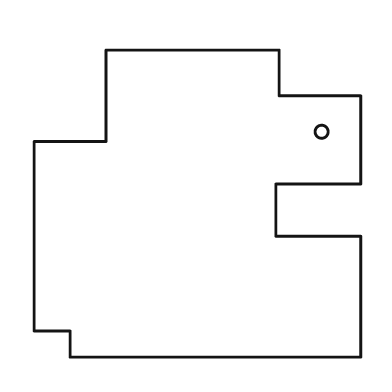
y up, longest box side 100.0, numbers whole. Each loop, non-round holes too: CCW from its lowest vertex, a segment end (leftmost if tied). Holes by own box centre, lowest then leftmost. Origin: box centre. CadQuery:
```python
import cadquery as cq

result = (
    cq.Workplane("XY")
    .moveTo(-39.0, -47.0)
    .lineTo(50.0, -47.0)
    .lineTo(50.0, -10.0)
    .lineTo(24.0, -10.0)
    .lineTo(24.0, 6.0)
    .lineTo(50.0, 6.0)
    .lineTo(50.0, 33.0)
    .lineTo(25.0, 33.0)
    .lineTo(25.0, 47.0)
    .lineTo(-28.0, 47.0)
    .lineTo(-28.0, 19.0)
    .lineTo(-50.0, 19.0)
    .lineTo(-50.0, -39.0)
    .lineTo(-39.0, -39.0)
    .close()
    .moveTo(38.0, 22.0)
    .circle(2.0)
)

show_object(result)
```